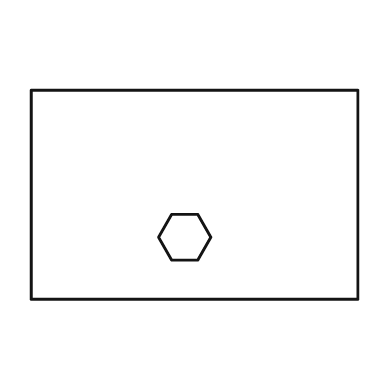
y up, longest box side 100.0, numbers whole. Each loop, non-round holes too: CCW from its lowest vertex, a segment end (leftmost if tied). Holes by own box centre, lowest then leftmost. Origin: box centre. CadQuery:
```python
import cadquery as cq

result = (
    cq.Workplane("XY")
    .moveTo(-50.0, -32.0)
    .lineTo(50.0, -32.0)
    .lineTo(50.0, 32.0)
    .lineTo(-50.0, 32.0)
    .close()
    .moveTo(-7.0, -20.0)
    .lineTo(1.0, -20.0)
    .lineTo(5.0, -13.0)
    .lineTo(1.0, -6.0)
    .lineTo(-7.0, -6.0)
    .lineTo(-11.0, -13.0)
    .close()
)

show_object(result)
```